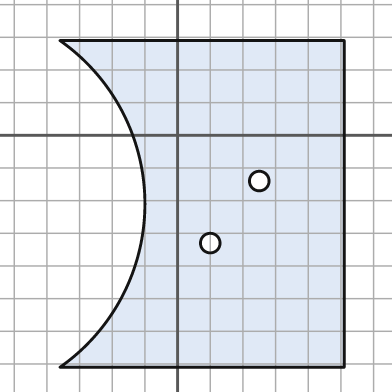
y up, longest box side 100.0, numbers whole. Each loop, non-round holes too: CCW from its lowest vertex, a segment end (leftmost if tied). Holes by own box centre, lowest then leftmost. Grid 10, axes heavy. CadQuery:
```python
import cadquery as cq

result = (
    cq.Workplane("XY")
    .moveTo(-36.0, -71.0)
    .lineTo(51.0, -71.0)
    .lineTo(51.0, 29.0)
    .lineTo(-36.0, 29.0)
    .threePointArc((-10.0, -21.0), (-36.0, -71.0))
    .close()
    .moveTo(10.0, -33.0)
    .circle(3.0)
    .moveTo(25.0, -14.0)
    .circle(3.0)
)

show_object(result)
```